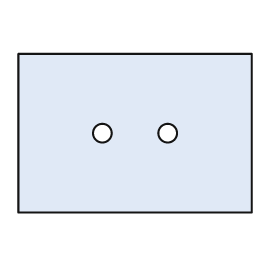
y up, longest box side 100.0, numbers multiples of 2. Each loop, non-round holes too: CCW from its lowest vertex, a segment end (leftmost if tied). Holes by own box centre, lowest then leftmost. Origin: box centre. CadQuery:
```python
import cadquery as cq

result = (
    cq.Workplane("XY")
    .moveTo(-50.0, -34.0)
    .lineTo(50.0, -34.0)
    .lineTo(50.0, 34.0)
    .lineTo(-50.0, 34.0)
    .close()
    .moveTo(-14.0, 0.0)
    .circle(4.0)
    .moveTo(14.0, 0.0)
    .circle(4.0)
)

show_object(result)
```